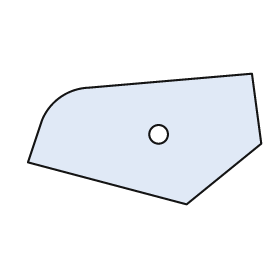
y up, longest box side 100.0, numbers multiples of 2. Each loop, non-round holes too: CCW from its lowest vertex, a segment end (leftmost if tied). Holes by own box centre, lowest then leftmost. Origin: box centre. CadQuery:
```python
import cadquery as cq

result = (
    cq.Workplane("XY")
    .moveTo(18.0, -28.0)
    .lineTo(50.0, -2.0)
    .lineTo(46.0, 28.0)
    .lineTo(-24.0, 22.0)
    .threePointArc((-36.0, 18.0), (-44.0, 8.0))
    .lineTo(-50.0, -10.0)
    .close()
    .moveTo(6.0, 2.0)
    .circle(4.0)
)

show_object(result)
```